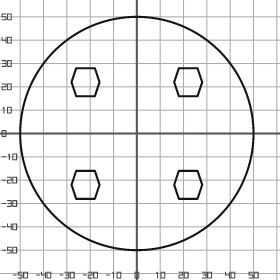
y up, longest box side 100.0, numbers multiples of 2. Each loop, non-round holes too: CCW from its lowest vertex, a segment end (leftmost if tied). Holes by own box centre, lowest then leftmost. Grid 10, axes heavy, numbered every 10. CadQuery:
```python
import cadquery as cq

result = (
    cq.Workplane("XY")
    .moveTo(0.0, 0.0)
    .circle(50.0)
    .moveTo(-26.0, -28.0)
    .lineTo(-18.0, -28.0)
    .lineTo(-16.0, -22.0)
    .lineTo(-18.0, -16.0)
    .lineTo(-26.0, -16.0)
    .lineTo(-28.0, -22.0)
    .close()
    .moveTo(18.0, -28.0)
    .lineTo(26.0, -28.0)
    .lineTo(28.0, -22.0)
    .lineTo(26.0, -16.0)
    .lineTo(18.0, -16.0)
    .lineTo(16.0, -22.0)
    .close()
    .moveTo(-26.0, 16.0)
    .lineTo(-18.0, 16.0)
    .lineTo(-16.0, 22.0)
    .lineTo(-18.0, 28.0)
    .lineTo(-26.0, 28.0)
    .lineTo(-28.0, 22.0)
    .close()
    .moveTo(18.0, 16.0)
    .lineTo(26.0, 16.0)
    .lineTo(28.0, 22.0)
    .lineTo(26.0, 28.0)
    .lineTo(18.0, 28.0)
    .lineTo(16.0, 22.0)
    .close()
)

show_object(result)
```